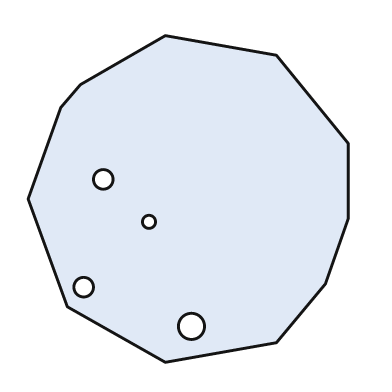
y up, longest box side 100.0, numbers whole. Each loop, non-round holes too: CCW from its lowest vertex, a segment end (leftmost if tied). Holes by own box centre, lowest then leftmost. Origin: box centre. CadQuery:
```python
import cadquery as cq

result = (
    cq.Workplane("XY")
    .moveTo(-7.0, -50.0)
    .lineTo(27.0, -44.0)
    .lineTo(42.0, -26.0)
    .lineTo(49.0, -6.0)
    .lineTo(49.0, 17.0)
    .lineTo(27.0, 44.0)
    .lineTo(-7.0, 50.0)
    .lineTo(-33.0, 35.0)
    .lineTo(-39.0, 28.0)
    .lineTo(-49.0, 0.0)
    .lineTo(-37.0, -33.0)
    .close()
    .moveTo(1.0, -39.0)
    .circle(4.0)
    .moveTo(-32.0, -27.0)
    .circle(3.0)
    .moveTo(-12.0, -7.0)
    .circle(2.0)
    .moveTo(-26.0, 6.0)
    .circle(3.0)
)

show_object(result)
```